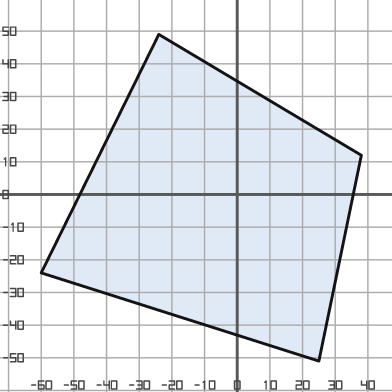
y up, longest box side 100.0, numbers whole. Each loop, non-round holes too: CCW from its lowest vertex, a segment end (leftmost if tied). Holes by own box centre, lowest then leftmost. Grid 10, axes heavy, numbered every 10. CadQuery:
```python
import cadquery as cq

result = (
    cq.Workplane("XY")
    .moveTo(25.0, -51.0)
    .lineTo(38.0, 12.0)
    .lineTo(-24.0, 49.0)
    .lineTo(-60.0, -24.0)
    .close()
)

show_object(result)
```